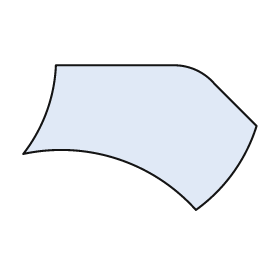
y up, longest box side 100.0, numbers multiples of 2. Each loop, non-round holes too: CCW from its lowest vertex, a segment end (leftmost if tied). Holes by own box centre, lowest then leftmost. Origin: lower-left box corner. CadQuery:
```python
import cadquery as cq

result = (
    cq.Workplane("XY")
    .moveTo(74.0, 0.0)
    .threePointArc((90.0, 16.0), (100.0, 36.0))
    .lineTo(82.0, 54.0)
    .threePointArc((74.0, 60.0), (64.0, 62.0))
    .lineTo(14.0, 62.0)
    .threePointArc((10.0, 42.0), (0.0, 24.0))
    .threePointArc((40.0, 22.0), (74.0, 0.0))
    .close()
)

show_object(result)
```